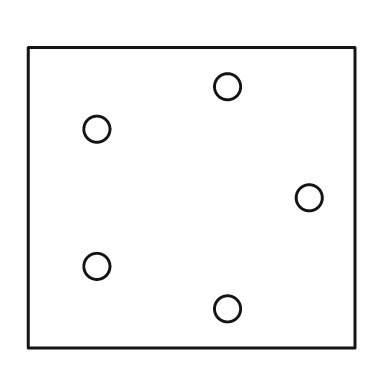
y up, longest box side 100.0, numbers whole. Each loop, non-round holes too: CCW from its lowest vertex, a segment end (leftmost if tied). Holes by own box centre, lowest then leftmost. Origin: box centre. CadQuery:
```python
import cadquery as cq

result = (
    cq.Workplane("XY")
    .moveTo(-50.0, -46.0)
    .lineTo(50.0, -46.0)
    .lineTo(50.0, 46.0)
    .lineTo(-50.0, 46.0)
    .close()
    .moveTo(11.0, -34.0)
    .circle(4.0)
    .moveTo(-29.0, -21.0)
    .circle(4.0)
    .moveTo(36.0, 0.0)
    .circle(4.0)
    .moveTo(-29.0, 21.0)
    .circle(4.0)
    .moveTo(11.0, 34.0)
    .circle(4.0)
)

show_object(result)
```